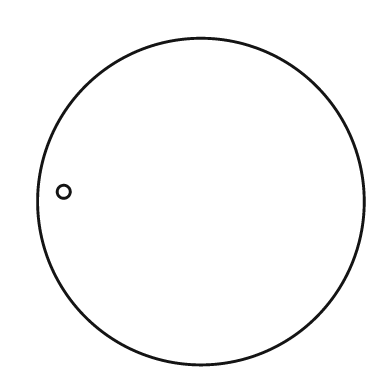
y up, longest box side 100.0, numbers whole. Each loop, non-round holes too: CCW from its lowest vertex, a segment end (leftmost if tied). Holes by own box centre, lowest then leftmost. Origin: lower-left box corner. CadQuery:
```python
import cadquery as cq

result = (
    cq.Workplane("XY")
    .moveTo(50.0, 50.0)
    .circle(50.0)
    .moveTo(8.0, 53.0)
    .circle(2.0)
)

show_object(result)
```